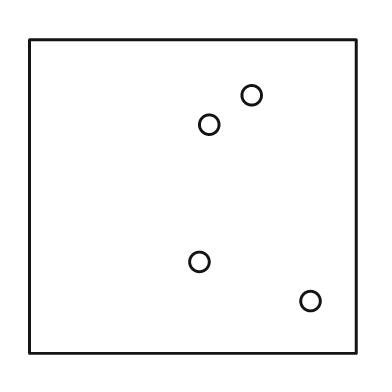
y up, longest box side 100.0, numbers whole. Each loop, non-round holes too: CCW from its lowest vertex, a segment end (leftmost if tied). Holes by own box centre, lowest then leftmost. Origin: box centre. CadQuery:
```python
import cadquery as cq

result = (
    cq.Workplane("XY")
    .moveTo(-50.0, -48.0)
    .lineTo(50.0, -48.0)
    .lineTo(50.0, 48.0)
    .lineTo(-50.0, 48.0)
    .close()
    .moveTo(36.0, -32.0)
    .circle(3.0)
    .moveTo(2.0, -20.0)
    .circle(3.0)
    .moveTo(5.0, 22.0)
    .circle(3.0)
    .moveTo(18.0, 31.0)
    .circle(3.0)
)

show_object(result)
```